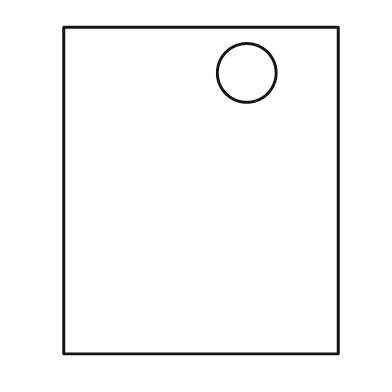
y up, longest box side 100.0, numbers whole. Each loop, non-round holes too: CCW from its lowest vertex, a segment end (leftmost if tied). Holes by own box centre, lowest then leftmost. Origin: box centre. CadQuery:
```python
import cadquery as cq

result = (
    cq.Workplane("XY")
    .moveTo(-42.0, -50.0)
    .lineTo(42.0, -50.0)
    .lineTo(42.0, 50.0)
    .lineTo(-42.0, 50.0)
    .close()
    .moveTo(14.0, 36.0)
    .circle(9.0)
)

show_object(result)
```